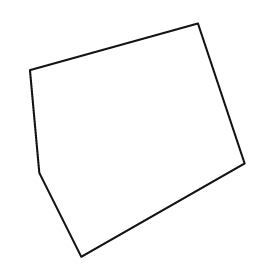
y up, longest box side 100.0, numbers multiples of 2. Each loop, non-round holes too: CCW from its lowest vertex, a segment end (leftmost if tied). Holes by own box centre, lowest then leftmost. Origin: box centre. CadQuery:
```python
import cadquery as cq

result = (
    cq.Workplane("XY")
    .moveTo(-24.0, -50.0)
    .lineTo(46.0, -10.0)
    .lineTo(26.0, 50.0)
    .lineTo(-46.0, 30.0)
    .lineTo(-42.0, -14.0)
    .close()
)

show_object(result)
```